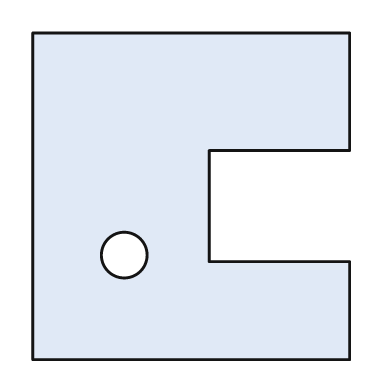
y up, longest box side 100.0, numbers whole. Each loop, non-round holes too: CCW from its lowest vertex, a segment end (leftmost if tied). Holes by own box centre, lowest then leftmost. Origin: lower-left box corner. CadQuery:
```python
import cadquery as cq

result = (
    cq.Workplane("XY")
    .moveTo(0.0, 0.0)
    .lineTo(97.0, 0.0)
    .lineTo(97.0, 30.0)
    .lineTo(54.0, 30.0)
    .lineTo(54.0, 64.0)
    .lineTo(97.0, 64.0)
    .lineTo(97.0, 100.0)
    .lineTo(0.0, 100.0)
    .close()
    .moveTo(28.0, 32.0)
    .circle(7.0)
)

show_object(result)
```